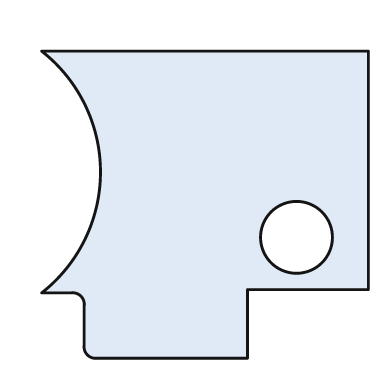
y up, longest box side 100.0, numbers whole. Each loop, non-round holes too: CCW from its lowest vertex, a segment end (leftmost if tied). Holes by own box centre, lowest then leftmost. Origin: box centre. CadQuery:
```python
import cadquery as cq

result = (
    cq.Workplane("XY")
    .moveTo(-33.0, -47.0)
    .lineTo(13.0, -47.0)
    .lineTo(13.0, -26.0)
    .lineTo(50.0, -26.0)
    .lineTo(50.0, 47.0)
    .lineTo(-50.0, 47.0)
    .threePointArc((-32.0, 10.0), (-50.0, -27.0))
    .lineTo(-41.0, -27.0)
    .threePointArc((-38.0, -28.0), (-37.0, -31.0))
    .lineTo(-37.0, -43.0)
    .threePointArc((-36.0, -46.0), (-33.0, -47.0))
    .close()
    .moveTo(28.0, -10.0)
    .circle(11.0)
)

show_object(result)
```